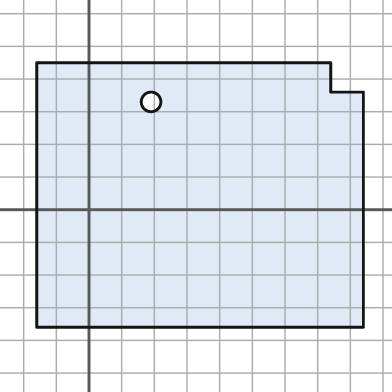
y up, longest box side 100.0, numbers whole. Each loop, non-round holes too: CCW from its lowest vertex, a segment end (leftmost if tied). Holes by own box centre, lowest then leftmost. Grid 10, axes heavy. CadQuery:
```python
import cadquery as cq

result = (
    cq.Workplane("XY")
    .moveTo(-16.0, -36.0)
    .lineTo(84.0, -36.0)
    .lineTo(84.0, 36.0)
    .lineTo(74.0, 36.0)
    .lineTo(74.0, 45.0)
    .lineTo(-16.0, 45.0)
    .close()
    .moveTo(19.0, 33.0)
    .circle(3.0)
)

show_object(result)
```